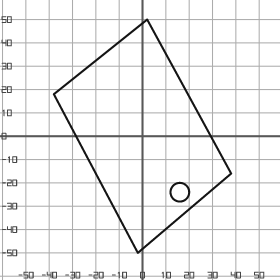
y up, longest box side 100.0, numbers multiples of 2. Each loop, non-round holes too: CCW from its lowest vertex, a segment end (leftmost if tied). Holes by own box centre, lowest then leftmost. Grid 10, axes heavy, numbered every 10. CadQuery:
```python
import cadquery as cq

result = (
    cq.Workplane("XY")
    .moveTo(-2.0, -50.0)
    .lineTo(38.0, -16.0)
    .lineTo(2.0, 50.0)
    .lineTo(-38.0, 18.0)
    .close()
    .moveTo(16.0, -24.0)
    .circle(4.0)
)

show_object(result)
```